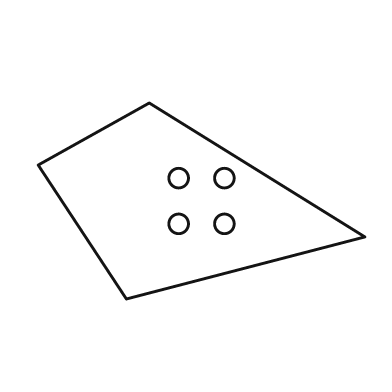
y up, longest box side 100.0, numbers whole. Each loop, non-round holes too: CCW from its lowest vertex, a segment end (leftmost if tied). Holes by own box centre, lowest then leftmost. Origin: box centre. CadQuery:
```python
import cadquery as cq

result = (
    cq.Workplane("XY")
    .moveTo(-23.0, -30.0)
    .lineTo(50.0, -11.0)
    .lineTo(-16.0, 30.0)
    .lineTo(-50.0, 11.0)
    .close()
    .moveTo(-7.0, -7.0)
    .circle(3.0)
    .moveTo(7.0, -7.0)
    .circle(3.0)
    .moveTo(-7.0, 7.0)
    .circle(3.0)
    .moveTo(7.0, 7.0)
    .circle(3.0)
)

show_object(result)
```